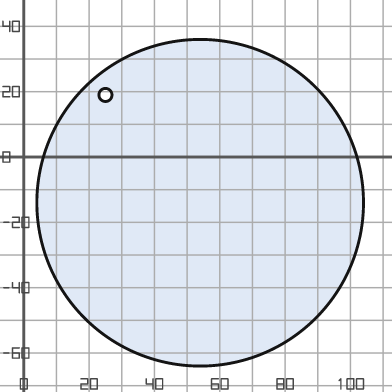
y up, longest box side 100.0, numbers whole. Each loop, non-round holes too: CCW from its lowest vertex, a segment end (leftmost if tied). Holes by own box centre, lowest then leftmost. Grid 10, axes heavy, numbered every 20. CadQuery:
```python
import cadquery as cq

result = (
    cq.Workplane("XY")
    .moveTo(54.0, -14.0)
    .circle(50.0)
    .moveTo(25.0, 19.0)
    .circle(2.0)
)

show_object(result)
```